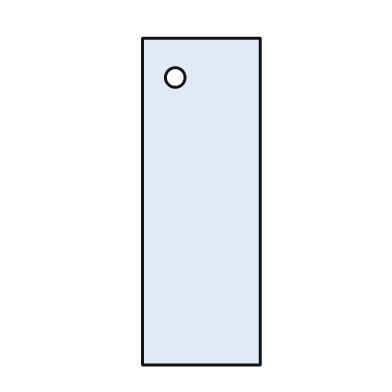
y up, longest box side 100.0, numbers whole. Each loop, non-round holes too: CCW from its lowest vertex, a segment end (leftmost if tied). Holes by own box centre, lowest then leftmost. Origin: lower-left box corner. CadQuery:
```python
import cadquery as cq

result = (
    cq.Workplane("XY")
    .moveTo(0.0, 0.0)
    .lineTo(36.0, 0.0)
    .lineTo(36.0, 100.0)
    .lineTo(0.0, 100.0)
    .close()
    .moveTo(10.0, 88.0)
    .circle(3.0)
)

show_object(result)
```